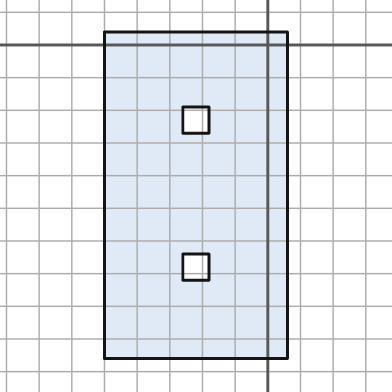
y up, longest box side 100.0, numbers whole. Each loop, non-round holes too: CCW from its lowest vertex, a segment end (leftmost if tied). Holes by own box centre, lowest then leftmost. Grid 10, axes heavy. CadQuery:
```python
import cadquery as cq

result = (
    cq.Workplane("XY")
    .moveTo(-50.0, -96.0)
    .lineTo(6.0, -96.0)
    .lineTo(6.0, 4.0)
    .lineTo(-50.0, 4.0)
    .close()
    .moveTo(-26.0, -72.0)
    .lineTo(-18.0, -72.0)
    .lineTo(-18.0, -64.0)
    .lineTo(-26.0, -64.0)
    .close()
    .moveTo(-26.0, -27.0)
    .lineTo(-18.0, -27.0)
    .lineTo(-18.0, -19.0)
    .lineTo(-26.0, -19.0)
    .close()
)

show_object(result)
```